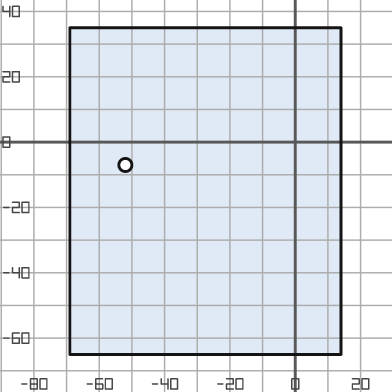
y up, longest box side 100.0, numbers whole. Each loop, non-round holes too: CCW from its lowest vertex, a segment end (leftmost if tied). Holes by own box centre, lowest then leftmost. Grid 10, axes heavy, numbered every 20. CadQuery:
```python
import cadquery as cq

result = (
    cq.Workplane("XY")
    .moveTo(-69.0, -65.0)
    .lineTo(14.0, -65.0)
    .lineTo(14.0, 35.0)
    .lineTo(-69.0, 35.0)
    .close()
    .moveTo(-52.0, -7.0)
    .circle(2.0)
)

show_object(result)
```